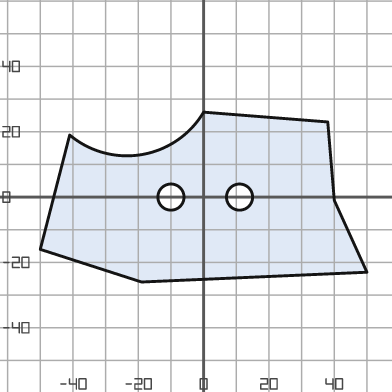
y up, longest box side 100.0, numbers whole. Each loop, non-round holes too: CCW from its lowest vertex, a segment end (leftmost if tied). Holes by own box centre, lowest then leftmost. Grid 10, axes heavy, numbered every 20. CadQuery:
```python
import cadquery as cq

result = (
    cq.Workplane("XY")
    .moveTo(-19.0, -26.0)
    .lineTo(50.0, -23.0)
    .lineTo(40.0, -1.0)
    .lineTo(38.0, 23.0)
    .lineTo(0.0, 26.0)
    .threePointArc((-19.0, 13.0), (-41.0, 19.0))
    .lineTo(-50.0, -16.0)
    .close()
    .moveTo(-10.0, 0.0)
    .circle(4.0)
    .moveTo(11.0, 0.0)
    .circle(4.0)
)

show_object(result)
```